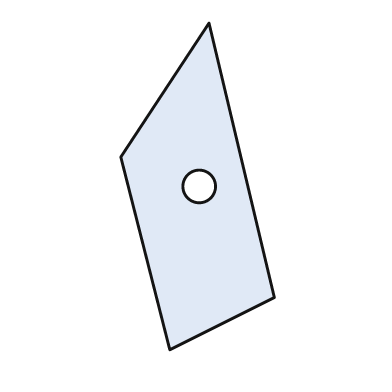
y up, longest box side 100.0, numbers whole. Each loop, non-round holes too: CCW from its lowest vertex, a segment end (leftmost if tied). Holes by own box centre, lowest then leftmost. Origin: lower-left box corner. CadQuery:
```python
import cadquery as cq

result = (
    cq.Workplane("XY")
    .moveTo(15.0, 0.0)
    .lineTo(47.0, 16.0)
    .lineTo(27.0, 100.0)
    .lineTo(0.0, 59.0)
    .close()
    .moveTo(24.0, 50.0)
    .circle(5.0)
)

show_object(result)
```